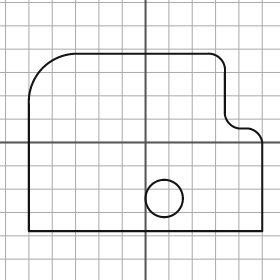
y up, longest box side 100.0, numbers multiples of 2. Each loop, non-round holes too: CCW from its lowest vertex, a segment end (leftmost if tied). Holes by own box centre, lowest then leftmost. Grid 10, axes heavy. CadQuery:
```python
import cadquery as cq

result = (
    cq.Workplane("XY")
    .moveTo(-50.0, -38.0)
    .lineTo(50.0, -38.0)
    .lineTo(50.0, 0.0)
    .threePointArc((48.0, 4.0), (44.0, 6.0))
    .lineTo(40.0, 6.0)
    .threePointArc((36.0, 8.0), (34.0, 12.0))
    .lineTo(34.0, 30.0)
    .threePointArc((32.0, 36.0), (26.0, 38.0))
    .lineTo(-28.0, 38.0)
    .threePointArc((-44.0, 32.0), (-50.0, 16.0))
    .close()
    .moveTo(8.0, -24.0)
    .circle(8.0)
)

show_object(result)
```